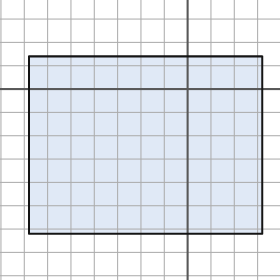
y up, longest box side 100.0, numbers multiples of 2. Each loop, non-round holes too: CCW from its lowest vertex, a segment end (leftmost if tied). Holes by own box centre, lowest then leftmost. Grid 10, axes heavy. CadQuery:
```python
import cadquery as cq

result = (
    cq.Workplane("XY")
    .moveTo(-68.0, -62.0)
    .lineTo(32.0, -62.0)
    .lineTo(32.0, 14.0)
    .lineTo(-68.0, 14.0)
    .close()
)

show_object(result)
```